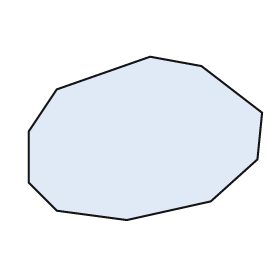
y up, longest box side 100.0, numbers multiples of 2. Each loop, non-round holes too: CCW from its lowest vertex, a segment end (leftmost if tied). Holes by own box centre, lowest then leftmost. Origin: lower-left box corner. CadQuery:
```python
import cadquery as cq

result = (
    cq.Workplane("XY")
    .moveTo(42.0, 0.0)
    .lineTo(78.0, 8.0)
    .lineTo(98.0, 26.0)
    .lineTo(100.0, 46.0)
    .lineTo(74.0, 66.0)
    .lineTo(52.0, 70.0)
    .lineTo(12.0, 56.0)
    .lineTo(0.0, 38.0)
    .lineTo(0.0, 16.0)
    .lineTo(12.0, 4.0)
    .close()
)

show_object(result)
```